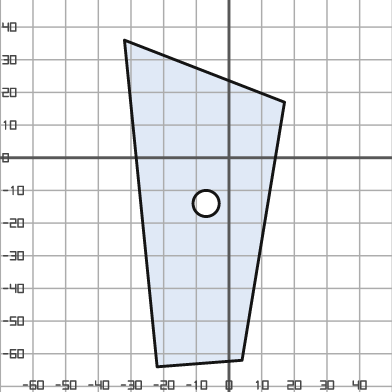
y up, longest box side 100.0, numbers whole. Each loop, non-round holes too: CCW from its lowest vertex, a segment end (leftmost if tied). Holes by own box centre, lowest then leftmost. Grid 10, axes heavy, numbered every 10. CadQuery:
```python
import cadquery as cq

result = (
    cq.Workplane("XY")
    .moveTo(-22.0, -64.0)
    .lineTo(4.0, -62.0)
    .lineTo(17.0, 17.0)
    .lineTo(-32.0, 36.0)
    .close()
    .moveTo(-7.0, -14.0)
    .circle(4.0)
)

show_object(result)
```